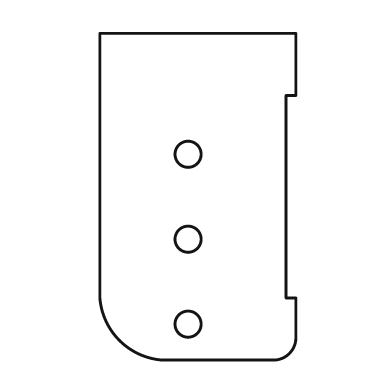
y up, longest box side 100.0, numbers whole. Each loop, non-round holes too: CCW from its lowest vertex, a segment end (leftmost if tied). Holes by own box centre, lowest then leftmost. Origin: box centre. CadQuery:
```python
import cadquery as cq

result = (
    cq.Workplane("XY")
    .moveTo(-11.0, -50.0)
    .lineTo(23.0, -50.0)
    .threePointArc((28.0, -48.0), (30.0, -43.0))
    .lineTo(30.0, -31.0)
    .lineTo(27.0, -31.0)
    .lineTo(27.0, 31.0)
    .lineTo(30.0, 31.0)
    .lineTo(30.0, 50.0)
    .lineTo(-30.0, 50.0)
    .lineTo(-30.0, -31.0)
    .threePointArc((-24.0, -44.0), (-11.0, -50.0))
    .close()
    .moveTo(-3.0, -39.0)
    .circle(4.0)
    .moveTo(-3.0, -13.0)
    .circle(4.0)
    .moveTo(-3.0, 13.0)
    .circle(4.0)
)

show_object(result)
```